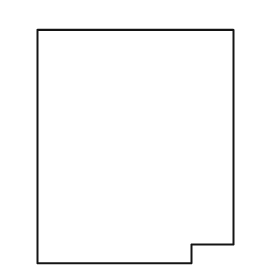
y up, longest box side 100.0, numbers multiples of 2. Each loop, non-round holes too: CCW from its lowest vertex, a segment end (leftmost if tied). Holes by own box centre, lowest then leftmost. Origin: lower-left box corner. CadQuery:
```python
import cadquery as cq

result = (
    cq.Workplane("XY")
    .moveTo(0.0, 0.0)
    .lineTo(66.0, 0.0)
    .lineTo(66.0, 8.0)
    .lineTo(84.0, 8.0)
    .lineTo(84.0, 100.0)
    .lineTo(0.0, 100.0)
    .close()
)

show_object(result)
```